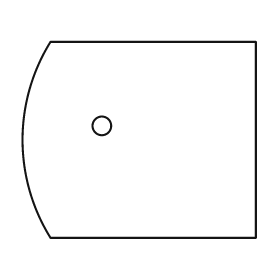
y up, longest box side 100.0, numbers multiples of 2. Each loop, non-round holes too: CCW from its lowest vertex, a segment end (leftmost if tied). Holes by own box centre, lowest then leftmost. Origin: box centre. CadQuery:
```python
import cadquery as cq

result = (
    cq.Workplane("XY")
    .moveTo(-38.0, -42.0)
    .lineTo(50.0, -42.0)
    .lineTo(50.0, 42.0)
    .lineTo(-38.0, 42.0)
    .threePointArc((-50.0, 0.0), (-38.0, -42.0))
    .close()
    .moveTo(-16.0, 6.0)
    .circle(4.0)
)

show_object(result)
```